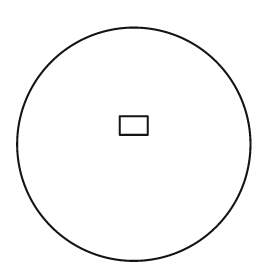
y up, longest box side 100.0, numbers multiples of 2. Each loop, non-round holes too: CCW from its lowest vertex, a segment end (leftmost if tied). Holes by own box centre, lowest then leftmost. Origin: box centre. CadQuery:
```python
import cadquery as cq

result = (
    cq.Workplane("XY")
    .moveTo(0.0, 0.0)
    .circle(50.0)
    .moveTo(-6.0, 4.0)
    .lineTo(6.0, 4.0)
    .lineTo(6.0, 12.0)
    .lineTo(-6.0, 12.0)
    .close()
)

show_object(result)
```